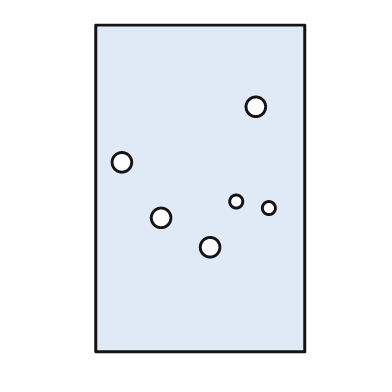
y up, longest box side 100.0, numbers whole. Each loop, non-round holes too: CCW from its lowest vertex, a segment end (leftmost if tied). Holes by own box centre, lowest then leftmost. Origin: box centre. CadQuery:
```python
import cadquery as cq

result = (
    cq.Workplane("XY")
    .moveTo(-32.0, -50.0)
    .lineTo(32.0, -50.0)
    .lineTo(32.0, 50.0)
    .lineTo(-32.0, 50.0)
    .close()
    .moveTo(3.0, -18.0)
    .circle(3.0)
    .moveTo(-12.0, -9.0)
    .circle(3.0)
    .moveTo(21.0, -6.0)
    .circle(2.0)
    .moveTo(11.0, -4.0)
    .circle(2.0)
    .moveTo(-24.0, 8.0)
    .circle(3.0)
    .moveTo(17.0, 25.0)
    .circle(3.0)
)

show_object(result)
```